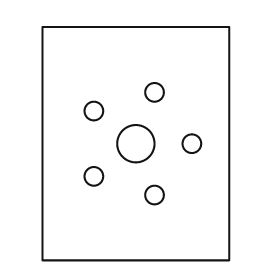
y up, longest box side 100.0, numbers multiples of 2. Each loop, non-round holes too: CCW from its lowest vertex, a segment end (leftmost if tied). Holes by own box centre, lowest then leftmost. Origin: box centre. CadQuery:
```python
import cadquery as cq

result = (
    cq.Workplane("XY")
    .moveTo(-40.0, -50.0)
    .lineTo(40.0, -50.0)
    .lineTo(40.0, 50.0)
    .lineTo(-40.0, 50.0)
    .close()
    .moveTo(8.0, -22.0)
    .circle(4.0)
    .moveTo(-18.0, -14.0)
    .circle(4.0)
    .moveTo(0.0, 0.0)
    .circle(8.0)
    .moveTo(24.0, 0.0)
    .circle(4.0)
    .moveTo(-18.0, 14.0)
    .circle(4.0)
    .moveTo(8.0, 22.0)
    .circle(4.0)
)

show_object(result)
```